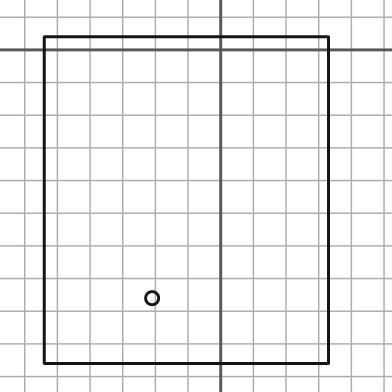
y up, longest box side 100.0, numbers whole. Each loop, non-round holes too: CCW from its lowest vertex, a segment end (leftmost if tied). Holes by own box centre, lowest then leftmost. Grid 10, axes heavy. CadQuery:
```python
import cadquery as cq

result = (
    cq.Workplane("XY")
    .moveTo(-54.0, -96.0)
    .lineTo(33.0, -96.0)
    .lineTo(33.0, 4.0)
    .lineTo(-54.0, 4.0)
    .close()
    .moveTo(-21.0, -76.0)
    .circle(2.0)
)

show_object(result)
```